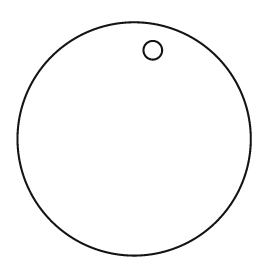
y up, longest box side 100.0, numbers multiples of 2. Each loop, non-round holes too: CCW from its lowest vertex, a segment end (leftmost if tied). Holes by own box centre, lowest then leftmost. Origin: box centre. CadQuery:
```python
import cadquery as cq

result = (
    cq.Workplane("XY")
    .moveTo(0.0, 0.0)
    .circle(50.0)
    .moveTo(8.0, 38.0)
    .circle(4.0)
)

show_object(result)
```